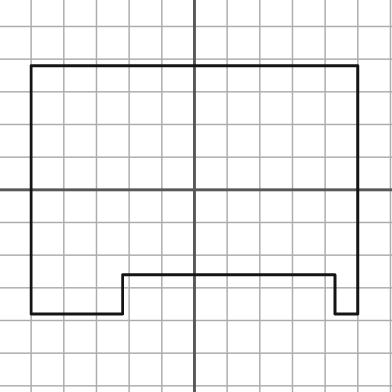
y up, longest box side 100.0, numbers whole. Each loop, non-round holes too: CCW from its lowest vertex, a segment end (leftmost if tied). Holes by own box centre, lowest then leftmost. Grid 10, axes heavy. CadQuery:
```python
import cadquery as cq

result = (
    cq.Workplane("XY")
    .moveTo(-50.0, -38.0)
    .lineTo(-22.0, -38.0)
    .lineTo(-22.0, -26.0)
    .lineTo(43.0, -26.0)
    .lineTo(43.0, -38.0)
    .lineTo(50.0, -38.0)
    .lineTo(50.0, 38.0)
    .lineTo(-50.0, 38.0)
    .close()
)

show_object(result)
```